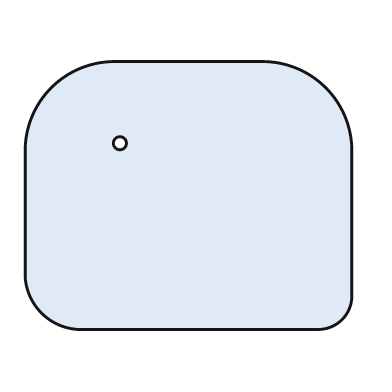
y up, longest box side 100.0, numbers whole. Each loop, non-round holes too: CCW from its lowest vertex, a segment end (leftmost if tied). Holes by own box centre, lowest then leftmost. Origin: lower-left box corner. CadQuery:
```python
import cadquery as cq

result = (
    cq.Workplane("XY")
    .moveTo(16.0, 0.0)
    .lineTo(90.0, 0.0)
    .threePointArc((97.0, 3.0), (100.0, 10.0))
    .lineTo(100.0, 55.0)
    .threePointArc((92.0, 74.0), (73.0, 82.0))
    .lineTo(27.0, 82.0)
    .threePointArc((8.0, 74.0), (0.0, 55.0))
    .lineTo(0.0, 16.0)
    .threePointArc((5.0, 5.0), (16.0, 0.0))
    .close()
    .moveTo(29.0, 57.0)
    .circle(2.0)
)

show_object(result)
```